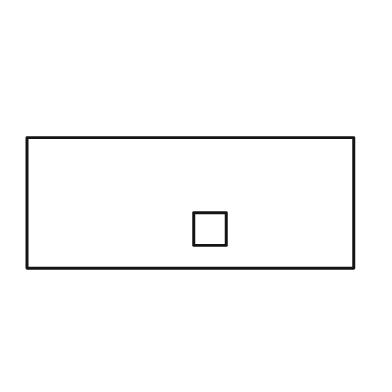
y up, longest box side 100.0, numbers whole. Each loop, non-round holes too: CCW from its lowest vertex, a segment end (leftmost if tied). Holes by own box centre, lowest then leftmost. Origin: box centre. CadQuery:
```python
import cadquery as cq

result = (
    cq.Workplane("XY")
    .moveTo(-50.0, -20.0)
    .lineTo(50.0, -20.0)
    .lineTo(50.0, 20.0)
    .lineTo(-50.0, 20.0)
    .close()
    .moveTo(1.0, -13.0)
    .lineTo(11.0, -13.0)
    .lineTo(11.0, -3.0)
    .lineTo(1.0, -3.0)
    .close()
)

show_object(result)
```